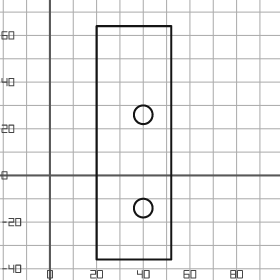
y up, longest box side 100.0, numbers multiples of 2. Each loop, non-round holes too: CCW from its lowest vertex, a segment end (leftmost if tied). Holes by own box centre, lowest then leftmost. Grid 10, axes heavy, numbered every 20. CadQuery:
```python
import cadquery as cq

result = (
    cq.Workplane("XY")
    .moveTo(20.0, -36.0)
    .lineTo(52.0, -36.0)
    .lineTo(52.0, 64.0)
    .lineTo(20.0, 64.0)
    .close()
    .moveTo(40.0, -14.0)
    .circle(4.0)
    .moveTo(40.0, 26.0)
    .circle(4.0)
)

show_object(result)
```